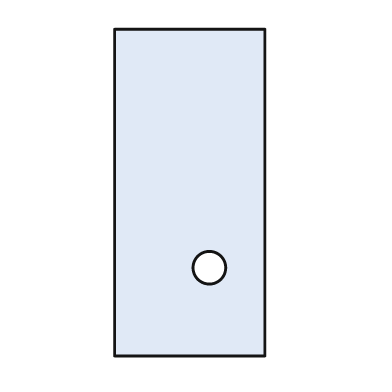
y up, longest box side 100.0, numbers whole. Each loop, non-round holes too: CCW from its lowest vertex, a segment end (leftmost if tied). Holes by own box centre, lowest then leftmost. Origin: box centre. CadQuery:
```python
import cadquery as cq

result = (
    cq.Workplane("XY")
    .moveTo(-23.0, -50.0)
    .lineTo(23.0, -50.0)
    .lineTo(23.0, 50.0)
    .lineTo(-23.0, 50.0)
    .close()
    .moveTo(6.0, -23.0)
    .circle(5.0)
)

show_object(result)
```